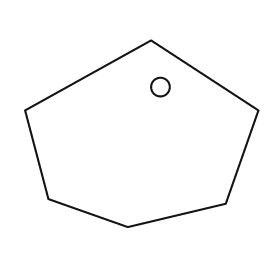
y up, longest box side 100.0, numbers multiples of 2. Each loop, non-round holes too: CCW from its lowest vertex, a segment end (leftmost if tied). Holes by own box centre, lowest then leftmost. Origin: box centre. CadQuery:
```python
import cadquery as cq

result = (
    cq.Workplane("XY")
    .moveTo(-6.0, -40.0)
    .lineTo(36.0, -30.0)
    .lineTo(50.0, 10.0)
    .lineTo(4.0, 40.0)
    .lineTo(-50.0, 10.0)
    .lineTo(-40.0, -28.0)
    .close()
    .moveTo(8.0, 20.0)
    .circle(4.0)
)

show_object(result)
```